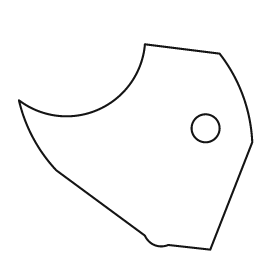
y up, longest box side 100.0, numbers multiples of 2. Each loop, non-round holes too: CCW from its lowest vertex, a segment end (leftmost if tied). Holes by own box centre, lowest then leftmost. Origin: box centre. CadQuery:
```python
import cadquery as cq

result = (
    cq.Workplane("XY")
    .moveTo(32.0, -44.0)
    .lineTo(50.0, 2.0)
    .threePointArc((46.0, 22.0), (36.0, 40.0))
    .lineTo(4.0, 44.0)
    .threePointArc((-16.0, 16.0), (-50.0, 20.0))
    .threePointArc((-44.0, 4.0), (-34.0, -10.0))
    .lineTo(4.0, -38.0)
    .threePointArc((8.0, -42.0), (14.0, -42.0))
    .close()
    .moveTo(30.0, 8.0)
    .circle(6.0)
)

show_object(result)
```